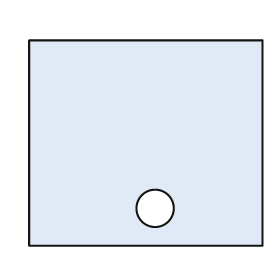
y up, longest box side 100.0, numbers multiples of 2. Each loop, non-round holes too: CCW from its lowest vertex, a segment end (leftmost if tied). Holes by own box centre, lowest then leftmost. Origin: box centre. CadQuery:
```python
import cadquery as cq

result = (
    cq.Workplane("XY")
    .moveTo(-50.0, -44.0)
    .lineTo(50.0, -44.0)
    .lineTo(50.0, 44.0)
    .lineTo(-50.0, 44.0)
    .close()
    .moveTo(4.0, -28.0)
    .circle(8.0)
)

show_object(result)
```